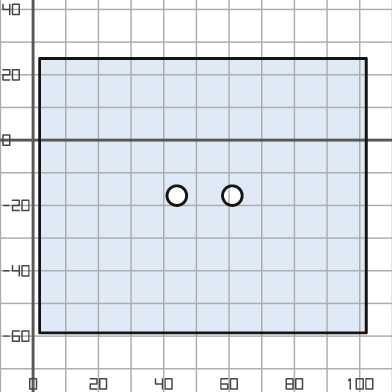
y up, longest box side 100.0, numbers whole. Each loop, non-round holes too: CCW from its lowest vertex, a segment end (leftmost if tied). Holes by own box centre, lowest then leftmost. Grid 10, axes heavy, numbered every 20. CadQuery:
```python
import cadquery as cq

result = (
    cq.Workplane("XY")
    .moveTo(2.0, -59.0)
    .lineTo(102.0, -59.0)
    .lineTo(102.0, 25.0)
    .lineTo(2.0, 25.0)
    .close()
    .moveTo(44.0, -17.0)
    .circle(3.0)
    .moveTo(61.0, -17.0)
    .circle(3.0)
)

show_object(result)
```